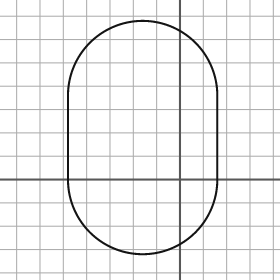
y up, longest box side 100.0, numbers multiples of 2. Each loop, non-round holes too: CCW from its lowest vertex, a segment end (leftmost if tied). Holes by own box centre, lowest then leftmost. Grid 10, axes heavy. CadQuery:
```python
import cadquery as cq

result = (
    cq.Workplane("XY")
    .moveTo(-48.0, 0.0)
    .threePointArc((-16.0, -32.0), (16.0, 0.0))
    .lineTo(16.0, 36.0)
    .threePointArc((-16.0, 68.0), (-48.0, 36.0))
    .close()
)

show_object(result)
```